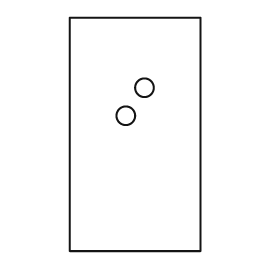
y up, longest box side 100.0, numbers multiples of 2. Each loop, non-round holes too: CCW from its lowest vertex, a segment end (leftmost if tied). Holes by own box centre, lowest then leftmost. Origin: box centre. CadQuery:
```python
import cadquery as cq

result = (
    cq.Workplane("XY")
    .moveTo(-28.0, -50.0)
    .lineTo(28.0, -50.0)
    .lineTo(28.0, 50.0)
    .lineTo(-28.0, 50.0)
    .close()
    .moveTo(-4.0, 8.0)
    .circle(4.0)
    .moveTo(4.0, 20.0)
    .circle(4.0)
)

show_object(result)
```